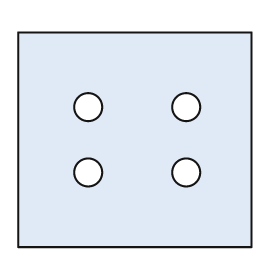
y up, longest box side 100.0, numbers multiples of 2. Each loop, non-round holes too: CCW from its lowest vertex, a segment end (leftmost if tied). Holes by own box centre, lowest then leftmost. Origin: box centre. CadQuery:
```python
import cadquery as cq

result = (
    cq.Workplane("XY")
    .moveTo(-50.0, -46.0)
    .lineTo(50.0, -46.0)
    .lineTo(50.0, 46.0)
    .lineTo(-50.0, 46.0)
    .close()
    .moveTo(-20.0, -14.0)
    .circle(6.0)
    .moveTo(22.0, -14.0)
    .circle(6.0)
    .moveTo(-20.0, 14.0)
    .circle(6.0)
    .moveTo(22.0, 14.0)
    .circle(6.0)
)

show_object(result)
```